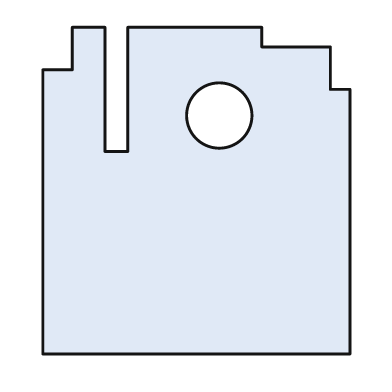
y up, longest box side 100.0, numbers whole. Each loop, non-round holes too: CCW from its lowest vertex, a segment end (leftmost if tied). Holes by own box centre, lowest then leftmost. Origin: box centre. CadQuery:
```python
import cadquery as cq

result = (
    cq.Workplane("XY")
    .moveTo(-47.0, -50.0)
    .lineTo(47.0, -50.0)
    .lineTo(47.0, 31.0)
    .lineTo(41.0, 31.0)
    .lineTo(41.0, 44.0)
    .lineTo(20.0, 44.0)
    .lineTo(20.0, 50.0)
    .lineTo(-21.0, 50.0)
    .lineTo(-21.0, 12.0)
    .lineTo(-28.0, 12.0)
    .lineTo(-28.0, 50.0)
    .lineTo(-38.0, 50.0)
    .lineTo(-38.0, 37.0)
    .lineTo(-47.0, 37.0)
    .close()
    .moveTo(7.0, 23.0)
    .circle(10.0)
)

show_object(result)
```